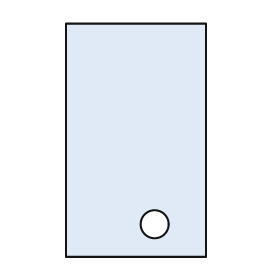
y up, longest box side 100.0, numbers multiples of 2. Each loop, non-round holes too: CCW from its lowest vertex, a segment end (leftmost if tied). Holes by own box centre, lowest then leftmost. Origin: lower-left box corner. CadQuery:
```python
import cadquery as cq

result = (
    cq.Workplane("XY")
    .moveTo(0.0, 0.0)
    .lineTo(60.0, 0.0)
    .lineTo(60.0, 100.0)
    .lineTo(0.0, 100.0)
    .close()
    .moveTo(38.0, 14.0)
    .circle(6.0)
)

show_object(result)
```